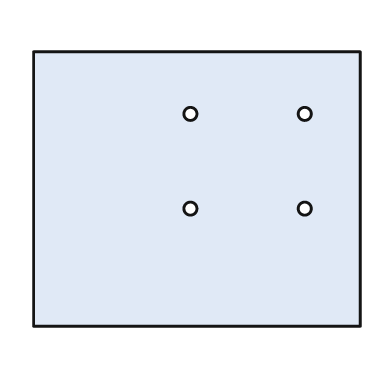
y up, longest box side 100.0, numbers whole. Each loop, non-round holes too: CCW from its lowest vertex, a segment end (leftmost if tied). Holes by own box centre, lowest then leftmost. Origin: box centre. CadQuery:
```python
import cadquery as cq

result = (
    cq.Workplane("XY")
    .moveTo(-50.0, -42.0)
    .lineTo(50.0, -42.0)
    .lineTo(50.0, 42.0)
    .lineTo(-50.0, 42.0)
    .close()
    .moveTo(-2.0, -6.0)
    .circle(2.0)
    .moveTo(33.0, -6.0)
    .circle(2.0)
    .moveTo(-2.0, 23.0)
    .circle(2.0)
    .moveTo(33.0, 23.0)
    .circle(2.0)
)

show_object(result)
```